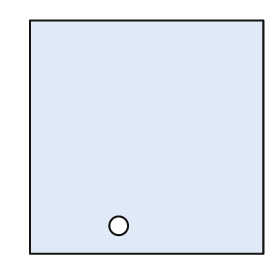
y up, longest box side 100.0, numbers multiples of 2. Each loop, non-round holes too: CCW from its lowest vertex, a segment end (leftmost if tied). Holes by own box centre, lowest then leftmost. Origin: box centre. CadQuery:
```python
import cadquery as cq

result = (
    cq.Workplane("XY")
    .moveTo(-50.0, -50.0)
    .lineTo(50.0, -50.0)
    .lineTo(50.0, 50.0)
    .lineTo(-50.0, 50.0)
    .close()
    .moveTo(-12.0, -38.0)
    .circle(4.0)
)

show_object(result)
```